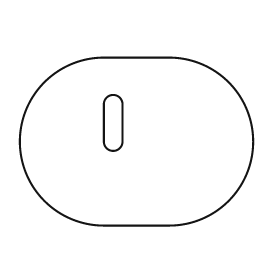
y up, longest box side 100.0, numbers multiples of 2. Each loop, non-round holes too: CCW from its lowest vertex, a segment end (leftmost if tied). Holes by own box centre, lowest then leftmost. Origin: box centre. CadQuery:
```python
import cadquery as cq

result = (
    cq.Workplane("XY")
    .moveTo(-14.0, -36.0)
    .lineTo(14.0, -36.0)
    .threePointArc((50.0, 0.0), (14.0, 36.0))
    .lineTo(-14.0, 36.0)
    .threePointArc((-50.0, 0.0), (-14.0, -36.0))
    .close()
    .moveTo(-14.0, 0.0)
    .threePointArc((-10.0, -4.0), (-6.0, 0.0))
    .lineTo(-6.0, 16.0)
    .threePointArc((-10.0, 20.0), (-14.0, 16.0))
    .close()
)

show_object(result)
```